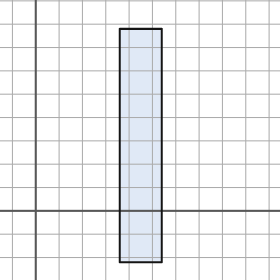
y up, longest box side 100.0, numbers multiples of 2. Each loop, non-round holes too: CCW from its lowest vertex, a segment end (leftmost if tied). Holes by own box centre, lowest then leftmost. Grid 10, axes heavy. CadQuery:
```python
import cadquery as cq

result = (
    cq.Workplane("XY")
    .moveTo(36.0, -22.0)
    .lineTo(54.0, -22.0)
    .lineTo(54.0, 78.0)
    .lineTo(36.0, 78.0)
    .close()
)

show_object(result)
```